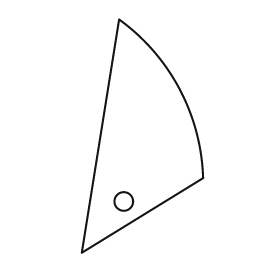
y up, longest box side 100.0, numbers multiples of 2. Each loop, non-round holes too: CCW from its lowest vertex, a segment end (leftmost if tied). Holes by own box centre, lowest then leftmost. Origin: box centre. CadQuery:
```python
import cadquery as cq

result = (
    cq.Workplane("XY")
    .moveTo(-26.0, -50.0)
    .lineTo(26.0, -18.0)
    .threePointArc((16.0, 20.0), (-10.0, 50.0))
    .close()
    .moveTo(-8.0, -28.0)
    .circle(4.0)
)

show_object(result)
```